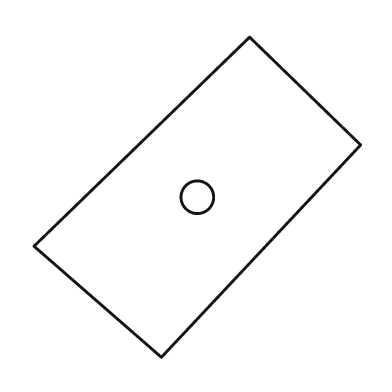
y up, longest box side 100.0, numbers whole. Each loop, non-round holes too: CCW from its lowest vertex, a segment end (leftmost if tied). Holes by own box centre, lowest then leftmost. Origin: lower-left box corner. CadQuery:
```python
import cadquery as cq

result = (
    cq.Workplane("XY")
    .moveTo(39.0, 0.0)
    .lineTo(100.0, 65.0)
    .lineTo(66.0, 98.0)
    .lineTo(0.0, 34.0)
    .close()
    .moveTo(50.0, 49.0)
    .circle(5.0)
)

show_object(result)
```